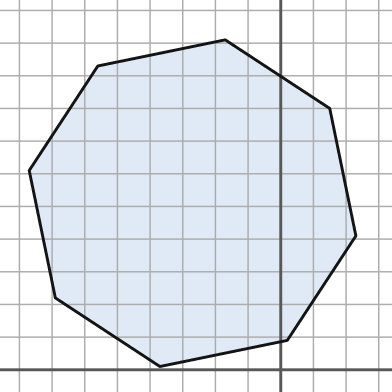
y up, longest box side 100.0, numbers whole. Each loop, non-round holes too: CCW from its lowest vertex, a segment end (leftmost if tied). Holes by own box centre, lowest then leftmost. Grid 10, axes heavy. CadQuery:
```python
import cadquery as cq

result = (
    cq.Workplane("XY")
    .moveTo(-37.0, 1.0)
    .lineTo(2.0, 9.0)
    .lineTo(23.0, 41.0)
    .lineTo(15.0, 80.0)
    .lineTo(-17.0, 101.0)
    .lineTo(-56.0, 93.0)
    .lineTo(-77.0, 61.0)
    .lineTo(-69.0, 22.0)
    .close()
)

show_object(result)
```